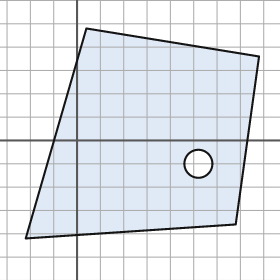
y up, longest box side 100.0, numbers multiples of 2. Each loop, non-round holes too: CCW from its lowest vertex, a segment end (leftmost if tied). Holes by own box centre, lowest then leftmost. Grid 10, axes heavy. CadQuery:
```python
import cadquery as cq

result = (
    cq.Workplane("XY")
    .moveTo(-22.0, -42.0)
    .lineTo(68.0, -36.0)
    .lineTo(78.0, 36.0)
    .lineTo(4.0, 48.0)
    .close()
    .moveTo(52.0, -10.0)
    .circle(6.0)
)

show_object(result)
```